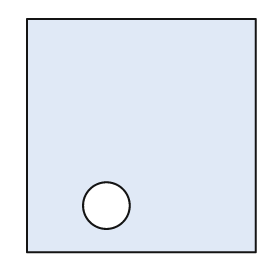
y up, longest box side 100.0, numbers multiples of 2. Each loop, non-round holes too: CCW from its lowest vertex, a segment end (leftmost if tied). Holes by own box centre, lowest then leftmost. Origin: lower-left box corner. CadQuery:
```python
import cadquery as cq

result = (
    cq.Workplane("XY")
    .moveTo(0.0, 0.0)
    .lineTo(98.0, 0.0)
    .lineTo(98.0, 100.0)
    .lineTo(0.0, 100.0)
    .close()
    .moveTo(34.0, 20.0)
    .circle(10.0)
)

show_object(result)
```